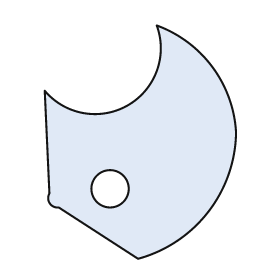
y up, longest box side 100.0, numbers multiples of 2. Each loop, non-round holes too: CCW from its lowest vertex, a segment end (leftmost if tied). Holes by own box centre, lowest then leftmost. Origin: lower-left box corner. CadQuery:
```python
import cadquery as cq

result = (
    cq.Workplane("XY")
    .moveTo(40.0, 0.0)
    .threePointArc((70.0, 20.0), (82.0, 54.0))
    .threePointArc((72.0, 82.0), (48.0, 100.0))
    .threePointArc((36.0, 66.0), (0.0, 72.0))
    .lineTo(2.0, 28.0)
    .threePointArc((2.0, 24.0), (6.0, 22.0))
    .close()
    .moveTo(28.0, 30.0)
    .circle(8.0)
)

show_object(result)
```